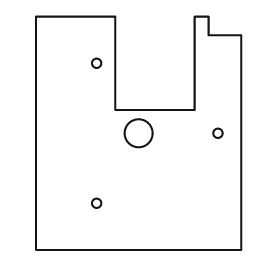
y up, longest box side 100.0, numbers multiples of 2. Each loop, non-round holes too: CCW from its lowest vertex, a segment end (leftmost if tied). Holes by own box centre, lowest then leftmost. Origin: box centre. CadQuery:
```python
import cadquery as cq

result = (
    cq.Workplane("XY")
    .moveTo(-44.0, -50.0)
    .lineTo(44.0, -50.0)
    .lineTo(44.0, 42.0)
    .lineTo(30.0, 42.0)
    .lineTo(30.0, 50.0)
    .lineTo(24.0, 50.0)
    .lineTo(24.0, 10.0)
    .lineTo(-10.0, 10.0)
    .lineTo(-10.0, 50.0)
    .lineTo(-44.0, 50.0)
    .close()
    .moveTo(-18.0, -30.0)
    .circle(2.0)
    .moveTo(0.0, 0.0)
    .circle(6.0)
    .moveTo(34.0, 0.0)
    .circle(2.0)
    .moveTo(-18.0, 30.0)
    .circle(2.0)
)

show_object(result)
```